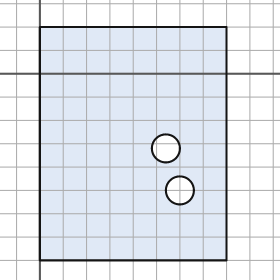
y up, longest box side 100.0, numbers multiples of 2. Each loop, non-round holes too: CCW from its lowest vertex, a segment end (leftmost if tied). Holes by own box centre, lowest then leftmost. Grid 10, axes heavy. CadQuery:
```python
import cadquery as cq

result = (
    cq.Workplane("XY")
    .moveTo(0.0, -80.0)
    .lineTo(80.0, -80.0)
    .lineTo(80.0, 20.0)
    .lineTo(0.0, 20.0)
    .close()
    .moveTo(60.0, -50.0)
    .circle(6.0)
    .moveTo(54.0, -32.0)
    .circle(6.0)
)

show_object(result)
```